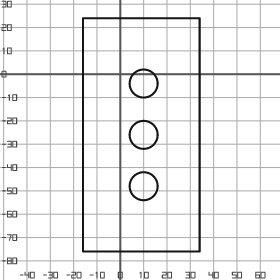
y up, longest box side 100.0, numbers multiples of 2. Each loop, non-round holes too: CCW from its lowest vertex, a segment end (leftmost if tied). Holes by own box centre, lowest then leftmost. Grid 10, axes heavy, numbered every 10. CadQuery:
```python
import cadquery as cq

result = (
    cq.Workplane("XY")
    .moveTo(-16.0, -76.0)
    .lineTo(34.0, -76.0)
    .lineTo(34.0, 24.0)
    .lineTo(-16.0, 24.0)
    .close()
    .moveTo(10.0, -48.0)
    .circle(6.0)
    .moveTo(10.0, -26.0)
    .circle(6.0)
    .moveTo(10.0, -4.0)
    .circle(6.0)
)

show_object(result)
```